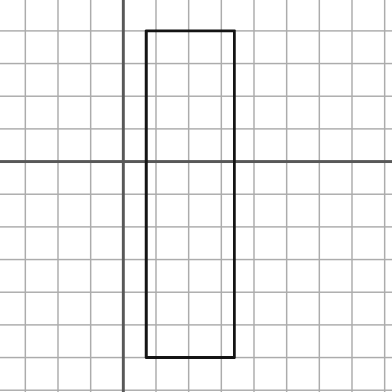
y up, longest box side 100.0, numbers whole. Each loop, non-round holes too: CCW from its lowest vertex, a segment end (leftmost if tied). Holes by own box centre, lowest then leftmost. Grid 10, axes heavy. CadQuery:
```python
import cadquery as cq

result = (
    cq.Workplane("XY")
    .moveTo(7.0, -60.0)
    .lineTo(34.0, -60.0)
    .lineTo(34.0, 40.0)
    .lineTo(7.0, 40.0)
    .close()
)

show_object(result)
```